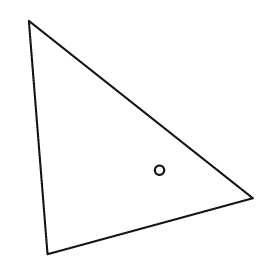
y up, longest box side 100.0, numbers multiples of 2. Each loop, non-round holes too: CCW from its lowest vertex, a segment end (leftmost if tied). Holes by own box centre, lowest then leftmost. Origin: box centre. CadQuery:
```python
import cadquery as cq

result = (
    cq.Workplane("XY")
    .moveTo(-40.0, -50.0)
    .lineTo(48.0, -26.0)
    .lineTo(-48.0, 50.0)
    .close()
    .moveTo(8.0, -14.0)
    .circle(2.0)
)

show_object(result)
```